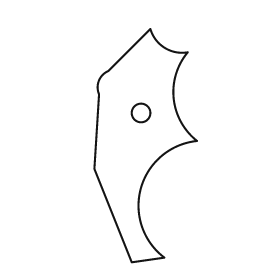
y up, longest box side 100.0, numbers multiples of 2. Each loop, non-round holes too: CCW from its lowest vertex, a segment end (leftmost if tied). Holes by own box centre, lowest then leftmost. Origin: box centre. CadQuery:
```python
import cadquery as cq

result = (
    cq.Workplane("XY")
    .moveTo(-6.0, -50.0)
    .lineTo(8.0, -48.0)
    .threePointArc((-2.0, -18.0), (22.0, 2.0))
    .threePointArc((12.0, 20.0), (18.0, 40.0))
    .threePointArc((8.0, 42.0), (2.0, 50.0))
    .lineTo(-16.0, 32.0)
    .threePointArc((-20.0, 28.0), (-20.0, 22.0))
    .lineTo(-22.0, -10.0)
    .close()
    .moveTo(-2.0, 14.0)
    .circle(4.0)
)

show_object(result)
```